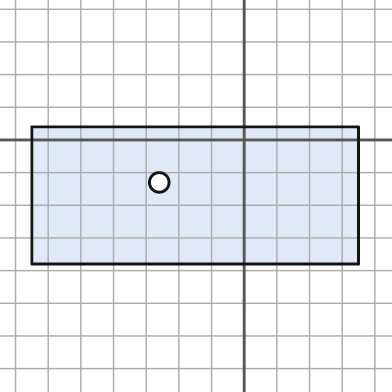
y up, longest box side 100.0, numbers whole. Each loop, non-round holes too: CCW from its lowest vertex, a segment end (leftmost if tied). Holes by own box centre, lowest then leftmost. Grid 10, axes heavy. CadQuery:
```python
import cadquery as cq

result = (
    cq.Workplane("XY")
    .moveTo(-65.0, -38.0)
    .lineTo(35.0, -38.0)
    .lineTo(35.0, 4.0)
    .lineTo(-65.0, 4.0)
    .close()
    .moveTo(-26.0, -13.0)
    .circle(3.0)
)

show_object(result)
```